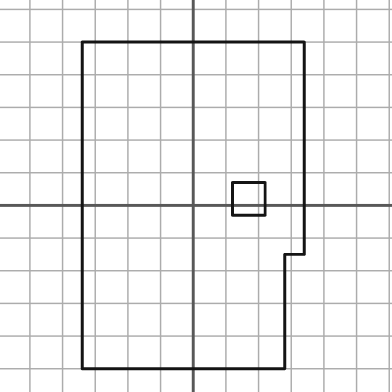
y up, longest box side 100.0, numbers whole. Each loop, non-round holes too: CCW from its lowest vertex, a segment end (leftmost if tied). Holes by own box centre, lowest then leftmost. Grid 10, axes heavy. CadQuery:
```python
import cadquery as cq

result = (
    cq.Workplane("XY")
    .moveTo(-34.0, -50.0)
    .lineTo(28.0, -50.0)
    .lineTo(28.0, -15.0)
    .lineTo(34.0, -15.0)
    .lineTo(34.0, 50.0)
    .lineTo(-34.0, 50.0)
    .close()
    .moveTo(12.0, -3.0)
    .lineTo(22.0, -3.0)
    .lineTo(22.0, 7.0)
    .lineTo(12.0, 7.0)
    .close()
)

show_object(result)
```